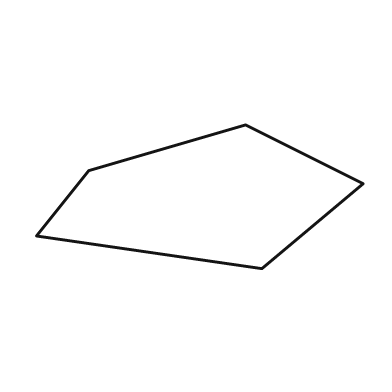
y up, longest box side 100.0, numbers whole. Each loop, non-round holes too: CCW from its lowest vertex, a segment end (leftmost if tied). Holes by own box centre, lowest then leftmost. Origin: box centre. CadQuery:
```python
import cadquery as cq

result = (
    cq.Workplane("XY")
    .moveTo(19.0, -22.0)
    .lineTo(50.0, 4.0)
    .lineTo(14.0, 22.0)
    .lineTo(-34.0, 8.0)
    .lineTo(-50.0, -12.0)
    .close()
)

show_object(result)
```